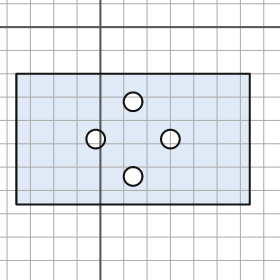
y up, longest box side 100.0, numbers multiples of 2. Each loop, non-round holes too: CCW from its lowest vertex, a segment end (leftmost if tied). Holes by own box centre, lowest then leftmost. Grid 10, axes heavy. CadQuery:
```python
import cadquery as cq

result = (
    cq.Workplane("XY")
    .moveTo(-36.0, -76.0)
    .lineTo(64.0, -76.0)
    .lineTo(64.0, -20.0)
    .lineTo(-36.0, -20.0)
    .close()
    .moveTo(14.0, -64.0)
    .circle(4.0)
    .moveTo(-2.0, -48.0)
    .circle(4.0)
    .moveTo(30.0, -48.0)
    .circle(4.0)
    .moveTo(14.0, -32.0)
    .circle(4.0)
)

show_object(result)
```